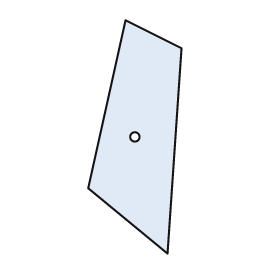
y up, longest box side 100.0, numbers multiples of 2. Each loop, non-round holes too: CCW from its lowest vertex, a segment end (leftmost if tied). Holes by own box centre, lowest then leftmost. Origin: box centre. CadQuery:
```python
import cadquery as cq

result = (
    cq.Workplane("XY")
    .moveTo(14.0, -50.0)
    .lineTo(20.0, 38.0)
    .lineTo(-4.0, 50.0)
    .lineTo(-20.0, -22.0)
    .close()
    .moveTo(0.0, 0.0)
    .circle(2.0)
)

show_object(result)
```